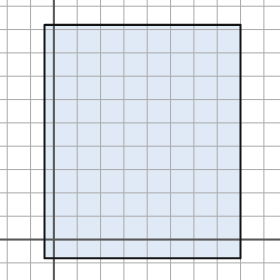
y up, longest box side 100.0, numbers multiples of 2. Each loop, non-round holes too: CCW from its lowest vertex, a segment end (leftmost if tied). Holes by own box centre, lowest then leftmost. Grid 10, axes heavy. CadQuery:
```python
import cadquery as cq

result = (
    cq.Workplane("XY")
    .moveTo(-4.0, -8.0)
    .lineTo(80.0, -8.0)
    .lineTo(80.0, 92.0)
    .lineTo(-4.0, 92.0)
    .close()
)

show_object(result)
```